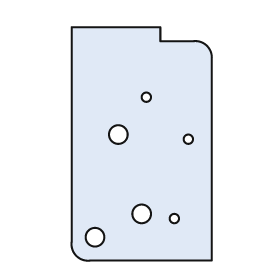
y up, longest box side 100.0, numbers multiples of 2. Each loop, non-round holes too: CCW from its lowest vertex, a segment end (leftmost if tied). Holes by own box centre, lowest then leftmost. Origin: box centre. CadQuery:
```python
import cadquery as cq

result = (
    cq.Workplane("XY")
    .moveTo(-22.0, -50.0)
    .lineTo(30.0, -50.0)
    .lineTo(30.0, 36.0)
    .threePointArc((28.0, 42.0), (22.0, 44.0))
    .lineTo(8.0, 44.0)
    .lineTo(8.0, 50.0)
    .lineTo(-30.0, 50.0)
    .lineTo(-30.0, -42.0)
    .threePointArc((-28.0, -48.0), (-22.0, -50.0))
    .close()
    .moveTo(-20.0, -40.0)
    .circle(4.0)
    .moveTo(14.0, -32.0)
    .circle(2.0)
    .moveTo(0.0, -30.0)
    .circle(4.0)
    .moveTo(20.0, 2.0)
    .circle(2.0)
    .moveTo(-10.0, 4.0)
    .circle(4.0)
    .moveTo(2.0, 20.0)
    .circle(2.0)
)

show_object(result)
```